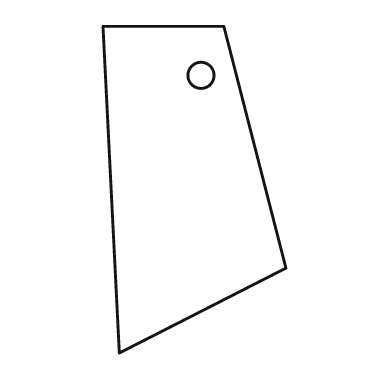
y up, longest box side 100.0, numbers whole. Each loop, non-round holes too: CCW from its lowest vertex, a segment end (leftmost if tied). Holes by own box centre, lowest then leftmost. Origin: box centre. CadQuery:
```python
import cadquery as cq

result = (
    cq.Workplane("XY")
    .moveTo(-23.0, -50.0)
    .lineTo(28.0, -24.0)
    .lineTo(9.0, 50.0)
    .lineTo(-28.0, 50.0)
    .close()
    .moveTo(2.0, 35.0)
    .circle(4.0)
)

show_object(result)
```